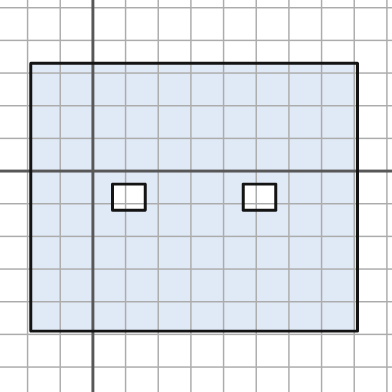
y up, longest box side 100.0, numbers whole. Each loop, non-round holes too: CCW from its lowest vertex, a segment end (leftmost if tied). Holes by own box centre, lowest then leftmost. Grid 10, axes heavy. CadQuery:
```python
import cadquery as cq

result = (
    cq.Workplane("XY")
    .moveTo(-19.0, -49.0)
    .lineTo(81.0, -49.0)
    .lineTo(81.0, 33.0)
    .lineTo(-19.0, 33.0)
    .close()
    .moveTo(6.0, -12.0)
    .lineTo(16.0, -12.0)
    .lineTo(16.0, -4.0)
    .lineTo(6.0, -4.0)
    .close()
    .moveTo(46.0, -12.0)
    .lineTo(56.0, -12.0)
    .lineTo(56.0, -4.0)
    .lineTo(46.0, -4.0)
    .close()
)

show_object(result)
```